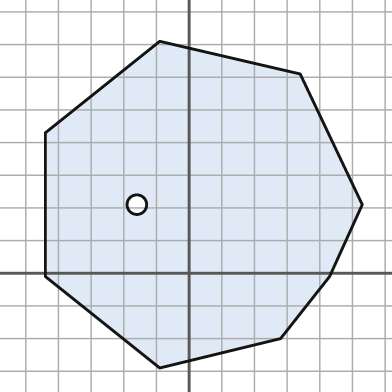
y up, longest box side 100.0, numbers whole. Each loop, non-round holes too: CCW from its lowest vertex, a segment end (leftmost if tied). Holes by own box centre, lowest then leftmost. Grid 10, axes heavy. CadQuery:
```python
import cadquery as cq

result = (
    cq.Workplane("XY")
    .moveTo(-9.0, -29.0)
    .lineTo(28.0, -20.0)
    .lineTo(43.0, -1.0)
    .lineTo(53.0, 21.0)
    .lineTo(34.0, 61.0)
    .lineTo(-9.0, 71.0)
    .lineTo(-44.0, 43.0)
    .lineTo(-44.0, -1.0)
    .close()
    .moveTo(-16.0, 21.0)
    .circle(3.0)
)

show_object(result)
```